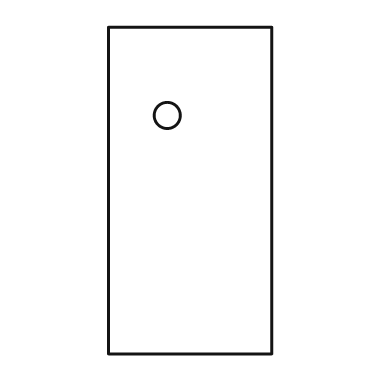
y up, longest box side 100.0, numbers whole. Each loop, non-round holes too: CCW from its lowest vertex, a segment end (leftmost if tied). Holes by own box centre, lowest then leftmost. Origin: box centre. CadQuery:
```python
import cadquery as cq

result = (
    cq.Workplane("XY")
    .moveTo(-25.0, -50.0)
    .lineTo(25.0, -50.0)
    .lineTo(25.0, 50.0)
    .lineTo(-25.0, 50.0)
    .close()
    .moveTo(-7.0, 23.0)
    .circle(4.0)
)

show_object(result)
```